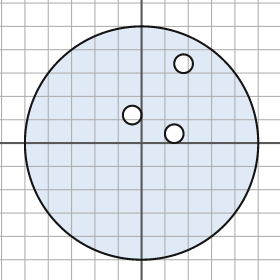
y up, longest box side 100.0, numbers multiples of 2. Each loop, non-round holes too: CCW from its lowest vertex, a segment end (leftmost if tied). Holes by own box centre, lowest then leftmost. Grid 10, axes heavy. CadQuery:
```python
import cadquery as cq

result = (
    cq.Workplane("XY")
    .moveTo(0.0, 0.0)
    .circle(50.0)
    .moveTo(14.0, 4.0)
    .circle(4.0)
    .moveTo(-4.0, 12.0)
    .circle(4.0)
    .moveTo(18.0, 34.0)
    .circle(4.0)
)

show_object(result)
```